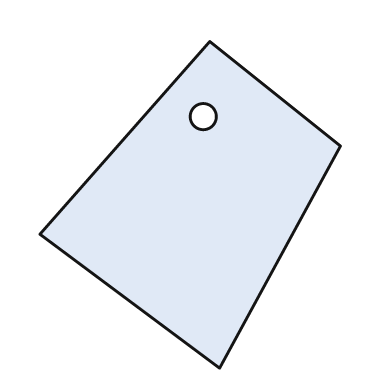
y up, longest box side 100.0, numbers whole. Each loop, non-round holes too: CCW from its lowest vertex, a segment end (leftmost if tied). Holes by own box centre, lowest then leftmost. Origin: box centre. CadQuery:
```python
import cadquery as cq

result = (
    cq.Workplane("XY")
    .moveTo(9.0, -50.0)
    .lineTo(46.0, 18.0)
    .lineTo(6.0, 50.0)
    .lineTo(-46.0, -9.0)
    .close()
    .moveTo(4.0, 27.0)
    .circle(4.0)
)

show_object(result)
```